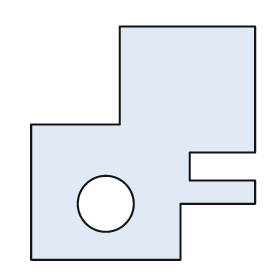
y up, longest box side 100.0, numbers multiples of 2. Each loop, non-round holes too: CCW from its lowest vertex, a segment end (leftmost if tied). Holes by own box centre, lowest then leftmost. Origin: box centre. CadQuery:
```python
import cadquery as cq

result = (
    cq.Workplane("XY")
    .moveTo(-48.0, -50.0)
    .lineTo(16.0, -50.0)
    .lineTo(16.0, -26.0)
    .lineTo(48.0, -26.0)
    .lineTo(48.0, -16.0)
    .lineTo(20.0, -16.0)
    .lineTo(20.0, -4.0)
    .lineTo(48.0, -4.0)
    .lineTo(48.0, 50.0)
    .lineTo(-10.0, 50.0)
    .lineTo(-10.0, 8.0)
    .lineTo(-48.0, 8.0)
    .close()
    .moveTo(-16.0, -26.0)
    .circle(12.0)
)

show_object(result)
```